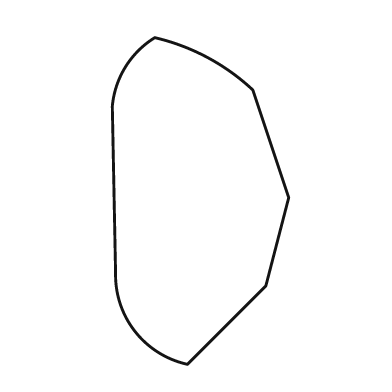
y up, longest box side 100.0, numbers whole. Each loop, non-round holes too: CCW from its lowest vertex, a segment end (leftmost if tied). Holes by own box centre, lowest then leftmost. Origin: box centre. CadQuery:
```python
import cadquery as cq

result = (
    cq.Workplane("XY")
    .moveTo(-4.0, -50.0)
    .lineTo(20.0, -26.0)
    .lineTo(27.0, 1.0)
    .lineTo(16.0, 34.0)
    .threePointArc((2.0, 44.0), (-14.0, 50.0))
    .threePointArc((-23.0, 41.0), (-27.0, 29.0))
    .lineTo(-26.0, -22.0)
    .threePointArc((-20.0, -40.0), (-4.0, -50.0))
    .close()
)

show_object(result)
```